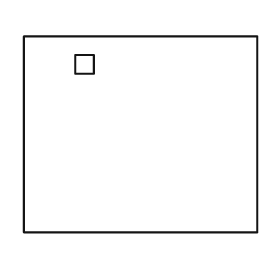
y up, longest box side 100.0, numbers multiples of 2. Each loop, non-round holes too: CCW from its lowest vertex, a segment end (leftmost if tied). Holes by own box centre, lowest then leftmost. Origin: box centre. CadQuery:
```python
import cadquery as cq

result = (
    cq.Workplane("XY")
    .moveTo(-50.0, -42.0)
    .lineTo(50.0, -42.0)
    .lineTo(50.0, 42.0)
    .lineTo(-50.0, 42.0)
    .close()
    .moveTo(-28.0, 26.0)
    .lineTo(-20.0, 26.0)
    .lineTo(-20.0, 34.0)
    .lineTo(-28.0, 34.0)
    .close()
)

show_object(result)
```